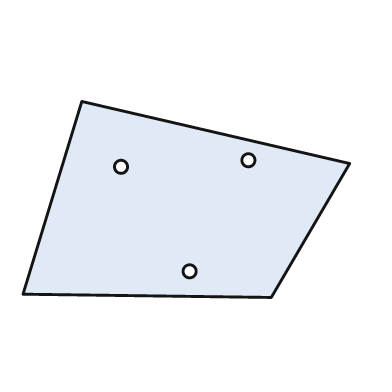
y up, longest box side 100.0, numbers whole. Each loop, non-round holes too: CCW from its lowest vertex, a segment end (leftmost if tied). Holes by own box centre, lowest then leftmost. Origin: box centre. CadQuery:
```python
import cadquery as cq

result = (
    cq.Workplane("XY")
    .moveTo(26.0, -30.0)
    .lineTo(50.0, 11.0)
    .lineTo(-32.0, 30.0)
    .lineTo(-50.0, -29.0)
    .close()
    .moveTo(1.0, -22.0)
    .circle(2.0)
    .moveTo(-20.0, 10.0)
    .circle(2.0)
    .moveTo(19.0, 12.0)
    .circle(2.0)
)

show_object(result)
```